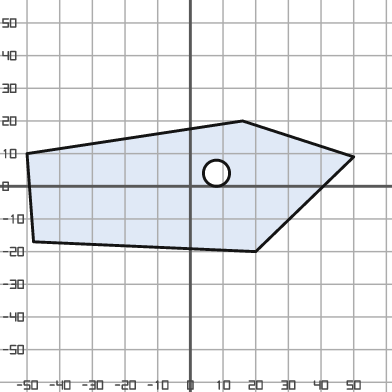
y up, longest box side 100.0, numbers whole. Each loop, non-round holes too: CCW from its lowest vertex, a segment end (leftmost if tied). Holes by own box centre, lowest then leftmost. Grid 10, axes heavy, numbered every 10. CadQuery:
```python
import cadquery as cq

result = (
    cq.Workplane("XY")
    .moveTo(20.0, -20.0)
    .lineTo(50.0, 9.0)
    .lineTo(16.0, 20.0)
    .lineTo(-50.0, 10.0)
    .lineTo(-48.0, -17.0)
    .close()
    .moveTo(8.0, 4.0)
    .circle(4.0)
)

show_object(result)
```